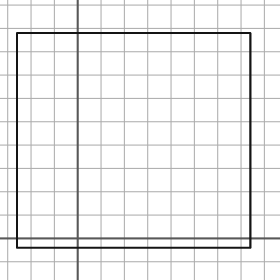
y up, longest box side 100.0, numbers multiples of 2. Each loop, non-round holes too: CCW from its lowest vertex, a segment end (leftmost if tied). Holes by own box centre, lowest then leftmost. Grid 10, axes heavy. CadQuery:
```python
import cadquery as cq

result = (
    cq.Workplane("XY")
    .moveTo(-26.0, -4.0)
    .lineTo(74.0, -4.0)
    .lineTo(74.0, 88.0)
    .lineTo(-26.0, 88.0)
    .close()
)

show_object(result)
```